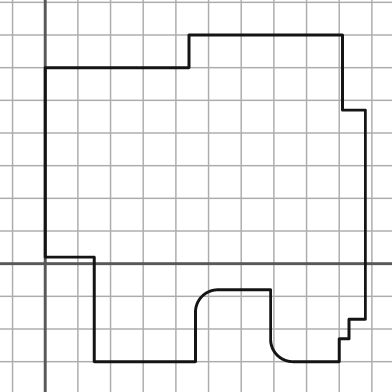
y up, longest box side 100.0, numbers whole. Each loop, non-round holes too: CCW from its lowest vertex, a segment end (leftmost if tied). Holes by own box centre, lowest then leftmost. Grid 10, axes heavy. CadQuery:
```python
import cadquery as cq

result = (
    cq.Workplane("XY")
    .moveTo(15.0, -30.0)
    .lineTo(46.0, -30.0)
    .lineTo(46.0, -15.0)
    .threePointArc((48.0, -10.0), (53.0, -8.0))
    .lineTo(69.0, -8.0)
    .lineTo(69.0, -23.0)
    .threePointArc((71.0, -28.0), (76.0, -30.0))
    .lineTo(90.0, -30.0)
    .lineTo(90.0, -23.0)
    .lineTo(93.0, -23.0)
    .lineTo(93.0, -17.0)
    .lineTo(98.0, -17.0)
    .lineTo(98.0, 47.0)
    .lineTo(91.0, 47.0)
    .lineTo(91.0, 70.0)
    .lineTo(44.0, 70.0)
    .lineTo(44.0, 60.0)
    .lineTo(0.0, 60.0)
    .lineTo(0.0, 2.0)
    .lineTo(15.0, 2.0)
    .close()
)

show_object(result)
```